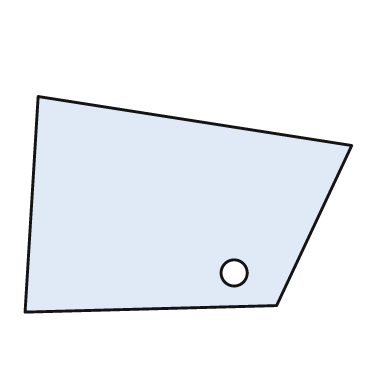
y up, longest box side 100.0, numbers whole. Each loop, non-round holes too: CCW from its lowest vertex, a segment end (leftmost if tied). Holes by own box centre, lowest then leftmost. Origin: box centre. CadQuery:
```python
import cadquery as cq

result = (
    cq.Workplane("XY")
    .moveTo(-50.0, -33.0)
    .lineTo(27.0, -31.0)
    .lineTo(50.0, 18.0)
    .lineTo(-46.0, 33.0)
    .close()
    .moveTo(14.0, -21.0)
    .circle(4.0)
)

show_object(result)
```